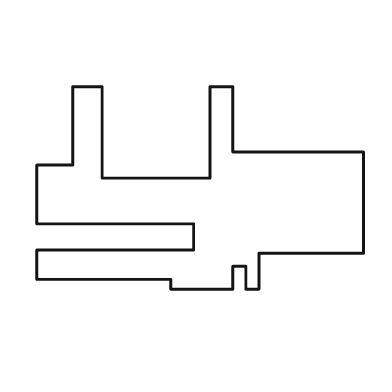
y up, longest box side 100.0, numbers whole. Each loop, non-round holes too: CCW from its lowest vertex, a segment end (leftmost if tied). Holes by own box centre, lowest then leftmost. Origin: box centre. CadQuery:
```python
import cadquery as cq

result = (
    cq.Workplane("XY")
    .moveTo(-9.0, -31.0)
    .lineTo(10.0, -31.0)
    .lineTo(10.0, -24.0)
    .lineTo(14.0, -24.0)
    .lineTo(14.0, -31.0)
    .lineTo(18.0, -31.0)
    .lineTo(18.0, -20.0)
    .lineTo(50.0, -20.0)
    .lineTo(50.0, 11.0)
    .lineTo(10.0, 11.0)
    .lineTo(10.0, 31.0)
    .lineTo(3.0, 31.0)
    .lineTo(3.0, 3.0)
    .lineTo(-30.0, 3.0)
    .lineTo(-30.0, 31.0)
    .lineTo(-39.0, 31.0)
    .lineTo(-39.0, 7.0)
    .lineTo(-50.0, 7.0)
    .lineTo(-50.0, -11.0)
    .lineTo(-2.0, -11.0)
    .lineTo(-2.0, -19.0)
    .lineTo(-50.0, -19.0)
    .lineTo(-50.0, -28.0)
    .lineTo(-9.0, -28.0)
    .close()
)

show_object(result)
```